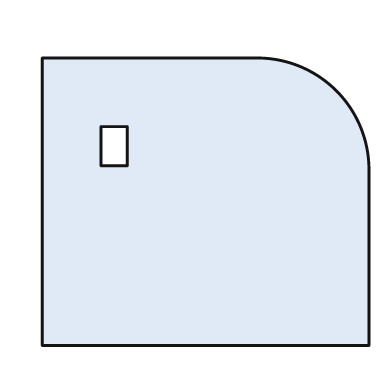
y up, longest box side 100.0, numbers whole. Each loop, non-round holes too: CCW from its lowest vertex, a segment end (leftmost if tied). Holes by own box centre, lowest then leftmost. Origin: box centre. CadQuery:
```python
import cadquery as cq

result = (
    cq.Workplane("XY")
    .moveTo(-50.0, -44.0)
    .lineTo(50.0, -44.0)
    .lineTo(50.0, 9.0)
    .threePointArc((40.0, 34.0), (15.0, 44.0))
    .lineTo(-50.0, 44.0)
    .close()
    .moveTo(-32.0, 11.0)
    .lineTo(-24.0, 11.0)
    .lineTo(-24.0, 23.0)
    .lineTo(-32.0, 23.0)
    .close()
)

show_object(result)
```